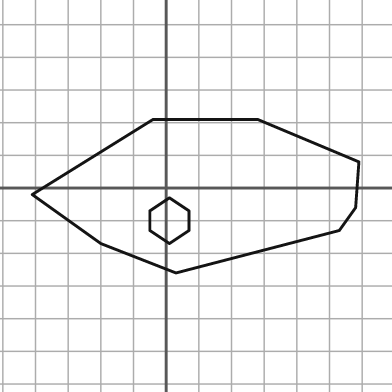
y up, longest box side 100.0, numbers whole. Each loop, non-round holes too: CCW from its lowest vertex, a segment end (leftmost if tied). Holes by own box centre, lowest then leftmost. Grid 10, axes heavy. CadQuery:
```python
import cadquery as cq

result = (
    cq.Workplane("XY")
    .moveTo(3.0, -26.0)
    .lineTo(53.0, -13.0)
    .lineTo(58.0, -6.0)
    .lineTo(59.0, 8.0)
    .lineTo(28.0, 21.0)
    .lineTo(-4.0, 21.0)
    .lineTo(-41.0, -2.0)
    .lineTo(-20.0, -17.0)
    .close()
    .moveTo(1.0, -17.0)
    .lineTo(7.0, -13.0)
    .lineTo(7.0, -7.0)
    .lineTo(1.0, -3.0)
    .lineTo(-5.0, -7.0)
    .lineTo(-5.0, -13.0)
    .close()
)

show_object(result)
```